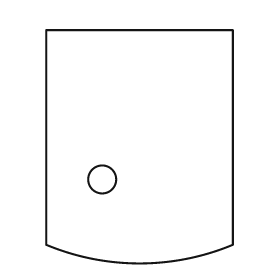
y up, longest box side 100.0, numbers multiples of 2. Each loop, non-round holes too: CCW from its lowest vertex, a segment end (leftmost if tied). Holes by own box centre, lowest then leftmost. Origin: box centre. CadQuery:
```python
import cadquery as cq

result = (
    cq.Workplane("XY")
    .moveTo(-40.0, -42.0)
    .threePointArc((0.0, -50.0), (40.0, -42.0))
    .lineTo(40.0, 50.0)
    .lineTo(-40.0, 50.0)
    .close()
    .moveTo(-16.0, -14.0)
    .circle(6.0)
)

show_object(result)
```